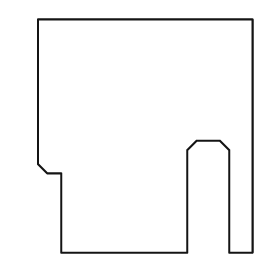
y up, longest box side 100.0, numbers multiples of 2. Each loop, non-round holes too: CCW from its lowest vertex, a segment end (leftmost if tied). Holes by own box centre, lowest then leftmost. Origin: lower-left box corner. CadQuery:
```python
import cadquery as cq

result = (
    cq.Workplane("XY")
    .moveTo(10.0, 0.0)
    .lineTo(64.0, 0.0)
    .lineTo(64.0, 44.0)
    .lineTo(68.0, 48.0)
    .lineTo(78.0, 48.0)
    .lineTo(82.0, 44.0)
    .lineTo(82.0, 0.0)
    .lineTo(92.0, 0.0)
    .lineTo(92.0, 100.0)
    .lineTo(0.0, 100.0)
    .lineTo(0.0, 38.0)
    .lineTo(4.0, 34.0)
    .lineTo(10.0, 34.0)
    .close()
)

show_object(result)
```